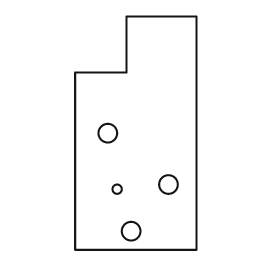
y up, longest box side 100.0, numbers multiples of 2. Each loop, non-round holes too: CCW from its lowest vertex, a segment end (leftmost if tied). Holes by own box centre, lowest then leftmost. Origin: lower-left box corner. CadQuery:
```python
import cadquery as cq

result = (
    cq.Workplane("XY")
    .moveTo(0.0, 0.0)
    .lineTo(52.0, 0.0)
    .lineTo(52.0, 100.0)
    .lineTo(22.0, 100.0)
    .lineTo(22.0, 76.0)
    .lineTo(0.0, 76.0)
    .close()
    .moveTo(24.0, 8.0)
    .circle(4.0)
    .moveTo(18.0, 26.0)
    .circle(2.0)
    .moveTo(40.0, 28.0)
    .circle(4.0)
    .moveTo(14.0, 50.0)
    .circle(4.0)
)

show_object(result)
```